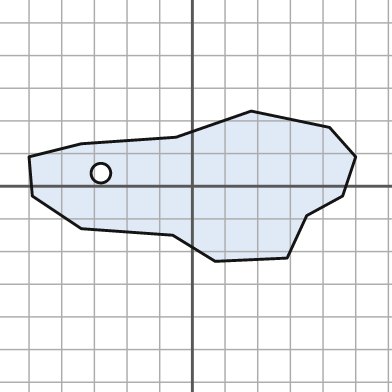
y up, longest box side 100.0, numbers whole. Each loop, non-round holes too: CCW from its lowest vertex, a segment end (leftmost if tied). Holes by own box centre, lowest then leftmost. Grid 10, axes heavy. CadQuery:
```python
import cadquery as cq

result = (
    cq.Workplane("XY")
    .moveTo(7.0, -23.0)
    .lineTo(29.0, -22.0)
    .lineTo(35.0, -9.0)
    .lineTo(46.0, -3.0)
    .lineTo(50.0, 9.0)
    .lineTo(42.0, 18.0)
    .lineTo(18.0, 23.0)
    .lineTo(-5.0, 15.0)
    .lineTo(-34.0, 13.0)
    .lineTo(-50.0, 9.0)
    .lineTo(-49.0, -3.0)
    .lineTo(-34.0, -13.0)
    .lineTo(-6.0, -15.0)
    .close()
    .moveTo(-28.0, 4.0)
    .circle(3.0)
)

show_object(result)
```